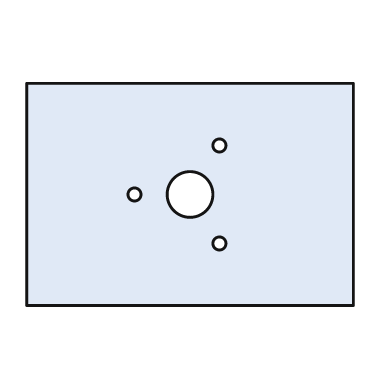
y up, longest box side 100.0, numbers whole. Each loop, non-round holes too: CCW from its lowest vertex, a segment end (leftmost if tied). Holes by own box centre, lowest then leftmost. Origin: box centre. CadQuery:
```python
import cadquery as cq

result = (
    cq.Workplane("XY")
    .moveTo(-50.0, -34.0)
    .lineTo(50.0, -34.0)
    .lineTo(50.0, 34.0)
    .lineTo(-50.0, 34.0)
    .close()
    .moveTo(9.0, -15.0)
    .circle(2.0)
    .moveTo(-17.0, 0.0)
    .circle(2.0)
    .moveTo(0.0, 0.0)
    .circle(7.0)
    .moveTo(9.0, 15.0)
    .circle(2.0)
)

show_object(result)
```